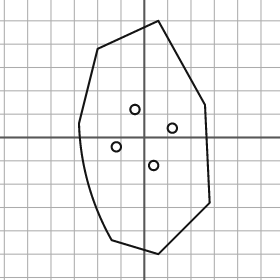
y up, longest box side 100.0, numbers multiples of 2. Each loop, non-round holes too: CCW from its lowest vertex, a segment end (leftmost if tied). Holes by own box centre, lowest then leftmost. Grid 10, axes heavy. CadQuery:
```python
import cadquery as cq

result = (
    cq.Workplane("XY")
    .moveTo(6.0, -50.0)
    .lineTo(28.0, -28.0)
    .lineTo(26.0, 14.0)
    .lineTo(6.0, 50.0)
    .lineTo(-20.0, 38.0)
    .lineTo(-28.0, 6.0)
    .threePointArc((-24.0, -20.0), (-14.0, -44.0))
    .close()
    .moveTo(4.0, -12.0)
    .circle(2.0)
    .moveTo(-12.0, -4.0)
    .circle(2.0)
    .moveTo(12.0, 4.0)
    .circle(2.0)
    .moveTo(-4.0, 12.0)
    .circle(2.0)
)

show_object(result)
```